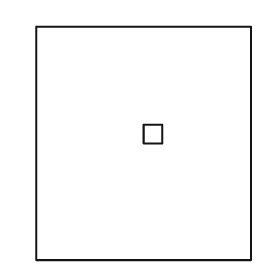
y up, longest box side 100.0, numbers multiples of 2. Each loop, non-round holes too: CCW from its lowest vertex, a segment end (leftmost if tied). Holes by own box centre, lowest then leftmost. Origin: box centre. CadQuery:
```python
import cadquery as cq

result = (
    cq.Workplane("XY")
    .moveTo(-46.0, -50.0)
    .lineTo(46.0, -50.0)
    .lineTo(46.0, 50.0)
    .lineTo(-46.0, 50.0)
    .close()
    .moveTo(0.0, 0.0)
    .lineTo(8.0, 0.0)
    .lineTo(8.0, 8.0)
    .lineTo(0.0, 8.0)
    .close()
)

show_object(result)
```